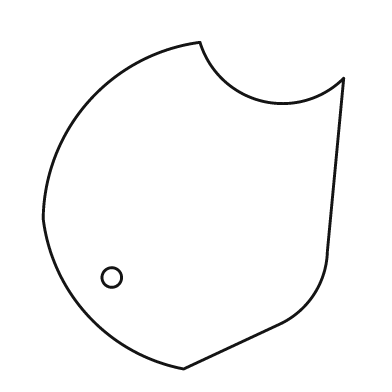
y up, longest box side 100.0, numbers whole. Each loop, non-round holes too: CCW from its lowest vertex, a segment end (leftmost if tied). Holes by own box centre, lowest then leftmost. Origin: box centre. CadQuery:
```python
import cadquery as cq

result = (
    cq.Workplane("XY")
    .moveTo(-3.0, -50.0)
    .lineTo(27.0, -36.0)
    .threePointArc((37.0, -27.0), (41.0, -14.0))
    .lineTo(46.0, 39.0)
    .threePointArc((21.0, 32.0), (2.0, 50.0))
    .threePointArc((-32.0, 32.0), (-46.0, -4.0))
    .threePointArc((-32.0, -34.0), (-3.0, -50.0))
    .close()
    .moveTo(-25.0, -22.0)
    .circle(3.0)
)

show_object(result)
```